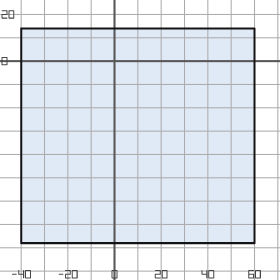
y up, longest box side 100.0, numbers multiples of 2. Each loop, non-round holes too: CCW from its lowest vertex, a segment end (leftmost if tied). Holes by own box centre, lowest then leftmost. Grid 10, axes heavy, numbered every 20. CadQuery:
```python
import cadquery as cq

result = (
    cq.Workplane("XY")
    .moveTo(-40.0, -78.0)
    .lineTo(60.0, -78.0)
    .lineTo(60.0, 14.0)
    .lineTo(-40.0, 14.0)
    .close()
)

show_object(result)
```